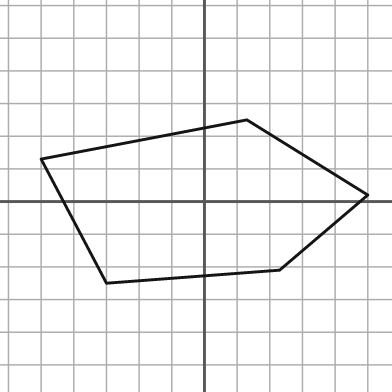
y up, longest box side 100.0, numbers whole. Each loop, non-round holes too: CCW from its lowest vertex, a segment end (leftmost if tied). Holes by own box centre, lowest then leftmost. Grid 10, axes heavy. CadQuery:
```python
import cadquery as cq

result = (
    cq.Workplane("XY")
    .moveTo(-30.0, -25.0)
    .lineTo(23.0, -21.0)
    .lineTo(50.0, 2.0)
    .lineTo(13.0, 25.0)
    .lineTo(-50.0, 13.0)
    .close()
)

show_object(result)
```